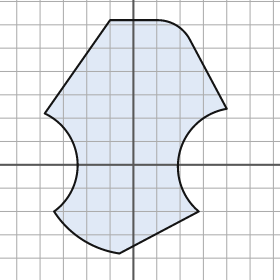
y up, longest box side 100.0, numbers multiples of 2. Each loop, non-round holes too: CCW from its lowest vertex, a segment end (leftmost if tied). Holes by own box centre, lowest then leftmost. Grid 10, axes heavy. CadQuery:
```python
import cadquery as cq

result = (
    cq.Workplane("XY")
    .moveTo(-6.0, -38.0)
    .lineTo(28.0, -20.0)
    .threePointArc((20.0, 6.0), (40.0, 24.0))
    .lineTo(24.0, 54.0)
    .threePointArc((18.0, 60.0), (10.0, 62.0))
    .lineTo(-10.0, 62.0)
    .lineTo(-38.0, 22.0)
    .threePointArc((-24.0, 2.0), (-34.0, -20.0))
    .threePointArc((-22.0, -32.0), (-6.0, -38.0))
    .close()
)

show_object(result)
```